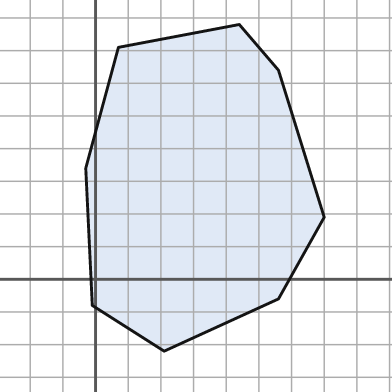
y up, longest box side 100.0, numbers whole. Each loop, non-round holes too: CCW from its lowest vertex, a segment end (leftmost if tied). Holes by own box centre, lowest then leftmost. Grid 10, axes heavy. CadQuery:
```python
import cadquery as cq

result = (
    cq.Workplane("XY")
    .moveTo(21.0, -22.0)
    .lineTo(56.0, -6.0)
    .lineTo(70.0, 19.0)
    .lineTo(56.0, 64.0)
    .lineTo(44.0, 78.0)
    .lineTo(7.0, 71.0)
    .lineTo(-3.0, 34.0)
    .lineTo(-1.0, -8.0)
    .close()
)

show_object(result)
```